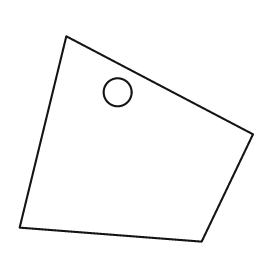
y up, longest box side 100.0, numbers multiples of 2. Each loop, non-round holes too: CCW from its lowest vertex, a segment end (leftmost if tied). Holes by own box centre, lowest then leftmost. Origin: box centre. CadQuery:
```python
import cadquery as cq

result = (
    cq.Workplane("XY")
    .moveTo(28.0, -44.0)
    .lineTo(50.0, 2.0)
    .lineTo(-30.0, 44.0)
    .lineTo(-50.0, -38.0)
    .close()
    .moveTo(-8.0, 20.0)
    .circle(6.0)
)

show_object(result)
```